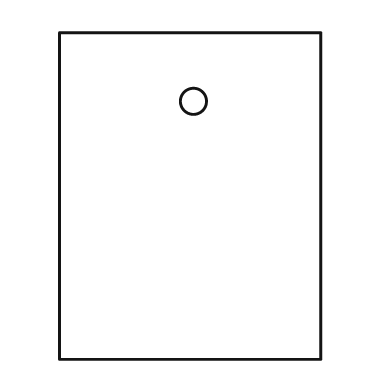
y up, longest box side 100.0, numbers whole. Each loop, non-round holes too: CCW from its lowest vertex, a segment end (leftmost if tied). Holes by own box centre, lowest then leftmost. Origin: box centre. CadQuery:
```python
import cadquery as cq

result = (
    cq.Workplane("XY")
    .moveTo(-40.0, -50.0)
    .lineTo(40.0, -50.0)
    .lineTo(40.0, 50.0)
    .lineTo(-40.0, 50.0)
    .close()
    .moveTo(1.0, 29.0)
    .circle(4.0)
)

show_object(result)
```